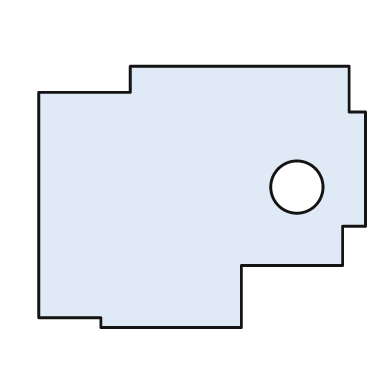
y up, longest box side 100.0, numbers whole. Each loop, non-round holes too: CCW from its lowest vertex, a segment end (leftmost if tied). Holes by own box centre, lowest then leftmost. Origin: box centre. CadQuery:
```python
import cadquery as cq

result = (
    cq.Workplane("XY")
    .moveTo(-31.0, -40.0)
    .lineTo(12.0, -40.0)
    .lineTo(12.0, -21.0)
    .lineTo(43.0, -21.0)
    .lineTo(43.0, -9.0)
    .lineTo(50.0, -9.0)
    .lineTo(50.0, 26.0)
    .lineTo(45.0, 26.0)
    .lineTo(45.0, 40.0)
    .lineTo(-22.0, 40.0)
    .lineTo(-22.0, 32.0)
    .lineTo(-50.0, 32.0)
    .lineTo(-50.0, -37.0)
    .lineTo(-31.0, -37.0)
    .close()
    .moveTo(29.0, 3.0)
    .circle(8.0)
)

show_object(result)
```